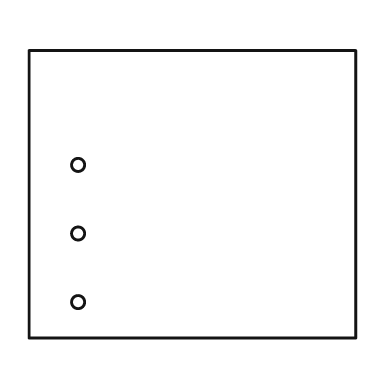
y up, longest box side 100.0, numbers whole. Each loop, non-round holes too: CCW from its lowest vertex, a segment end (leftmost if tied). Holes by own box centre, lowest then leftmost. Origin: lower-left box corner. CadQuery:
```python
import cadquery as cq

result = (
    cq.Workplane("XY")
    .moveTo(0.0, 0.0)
    .lineTo(100.0, 0.0)
    .lineTo(100.0, 88.0)
    .lineTo(0.0, 88.0)
    .close()
    .moveTo(15.0, 11.0)
    .circle(2.0)
    .moveTo(15.0, 32.0)
    .circle(2.0)
    .moveTo(15.0, 53.0)
    .circle(2.0)
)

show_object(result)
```